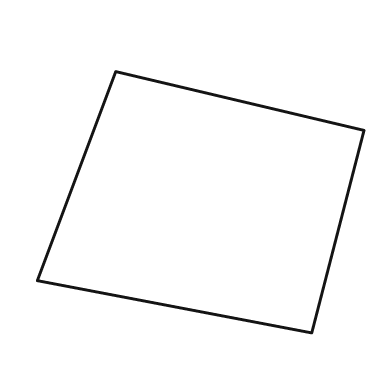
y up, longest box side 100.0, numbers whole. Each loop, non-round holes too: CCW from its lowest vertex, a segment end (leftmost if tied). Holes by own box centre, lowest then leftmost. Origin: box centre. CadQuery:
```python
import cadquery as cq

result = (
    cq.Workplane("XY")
    .moveTo(34.0, -40.0)
    .lineTo(50.0, 22.0)
    .lineTo(-26.0, 40.0)
    .lineTo(-50.0, -24.0)
    .close()
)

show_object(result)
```